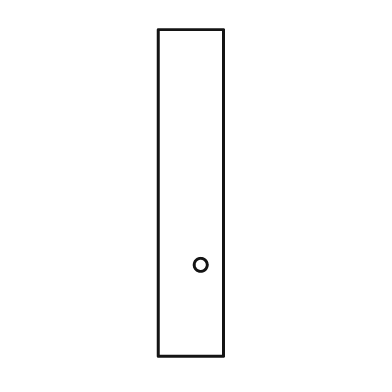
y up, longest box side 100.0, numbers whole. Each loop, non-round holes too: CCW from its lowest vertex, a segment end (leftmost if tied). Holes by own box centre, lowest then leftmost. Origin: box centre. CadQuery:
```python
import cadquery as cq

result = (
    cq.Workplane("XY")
    .moveTo(-10.0, -50.0)
    .lineTo(10.0, -50.0)
    .lineTo(10.0, 50.0)
    .lineTo(-10.0, 50.0)
    .close()
    .moveTo(3.0, -22.0)
    .circle(2.0)
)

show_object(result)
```